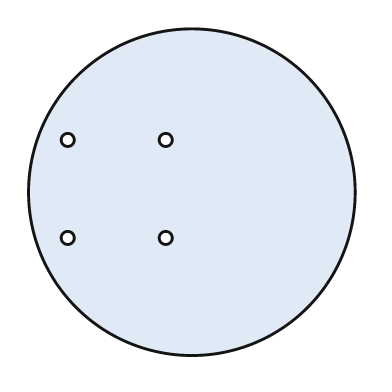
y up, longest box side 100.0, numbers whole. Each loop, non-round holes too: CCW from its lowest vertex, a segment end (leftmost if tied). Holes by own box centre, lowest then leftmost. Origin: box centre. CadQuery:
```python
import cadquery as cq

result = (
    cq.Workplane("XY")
    .moveTo(0.0, 0.0)
    .circle(50.0)
    .moveTo(-38.0, -14.0)
    .circle(2.0)
    .moveTo(-8.0, -14.0)
    .circle(2.0)
    .moveTo(-38.0, 16.0)
    .circle(2.0)
    .moveTo(-8.0, 16.0)
    .circle(2.0)
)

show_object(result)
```